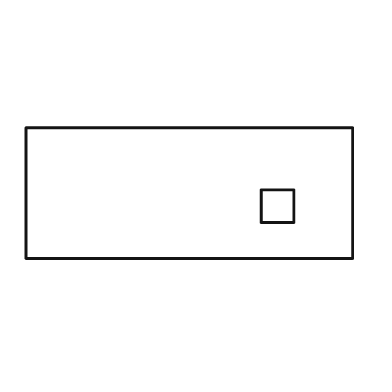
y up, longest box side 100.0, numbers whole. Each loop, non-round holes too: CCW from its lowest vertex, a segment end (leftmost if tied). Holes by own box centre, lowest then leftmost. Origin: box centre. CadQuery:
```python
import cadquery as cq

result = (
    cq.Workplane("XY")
    .moveTo(-50.0, -20.0)
    .lineTo(50.0, -20.0)
    .lineTo(50.0, 20.0)
    .lineTo(-50.0, 20.0)
    .close()
    .moveTo(22.0, -9.0)
    .lineTo(32.0, -9.0)
    .lineTo(32.0, 1.0)
    .lineTo(22.0, 1.0)
    .close()
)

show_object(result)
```